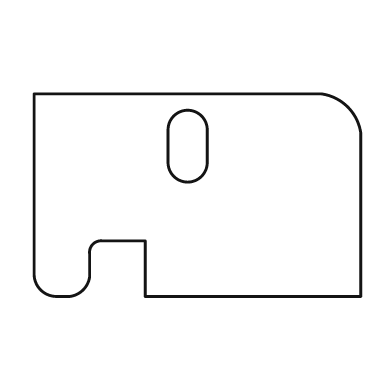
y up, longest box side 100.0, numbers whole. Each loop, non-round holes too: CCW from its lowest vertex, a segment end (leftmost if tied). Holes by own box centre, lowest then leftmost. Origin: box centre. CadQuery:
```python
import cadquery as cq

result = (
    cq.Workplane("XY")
    .moveTo(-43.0, -31.0)
    .lineTo(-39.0, -31.0)
    .threePointArc((-35.0, -29.0), (-33.0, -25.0))
    .lineTo(-33.0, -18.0)
    .threePointArc((-32.0, -15.0), (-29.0, -14.0))
    .lineTo(-16.0, -14.0)
    .lineTo(-16.0, -31.0)
    .lineTo(50.0, -31.0)
    .lineTo(50.0, 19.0)
    .threePointArc((46.0, 27.0), (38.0, 31.0))
    .lineTo(-50.0, 31.0)
    .lineTo(-50.0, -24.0)
    .threePointArc((-48.0, -29.0), (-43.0, -31.0))
    .close()
    .moveTo(-9.0, 10.0)
    .threePointArc((-3.0, 4.0), (3.0, 10.0))
    .lineTo(3.0, 20.0)
    .threePointArc((-3.0, 26.0), (-9.0, 20.0))
    .close()
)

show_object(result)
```